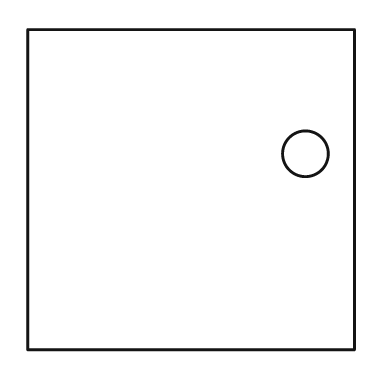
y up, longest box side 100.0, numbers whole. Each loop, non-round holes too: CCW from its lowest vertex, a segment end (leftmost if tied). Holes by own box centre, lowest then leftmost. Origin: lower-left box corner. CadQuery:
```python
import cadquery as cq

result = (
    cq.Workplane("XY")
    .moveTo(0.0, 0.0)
    .lineTo(100.0, 0.0)
    .lineTo(100.0, 98.0)
    .lineTo(0.0, 98.0)
    .close()
    .moveTo(85.0, 60.0)
    .circle(7.0)
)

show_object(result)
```